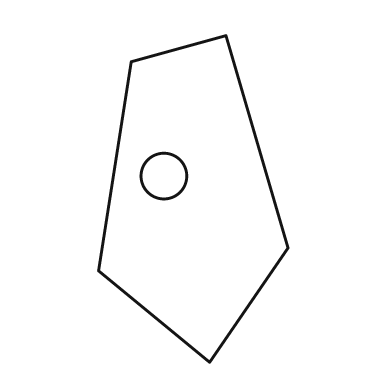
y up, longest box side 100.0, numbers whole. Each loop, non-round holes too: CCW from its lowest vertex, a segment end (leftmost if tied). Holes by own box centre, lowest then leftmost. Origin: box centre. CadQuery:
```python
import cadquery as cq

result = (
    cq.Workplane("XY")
    .moveTo(5.0, -50.0)
    .lineTo(29.0, -15.0)
    .lineTo(10.0, 50.0)
    .lineTo(-19.0, 42.0)
    .lineTo(-29.0, -22.0)
    .close()
    .moveTo(-9.0, 7.0)
    .circle(7.0)
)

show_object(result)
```